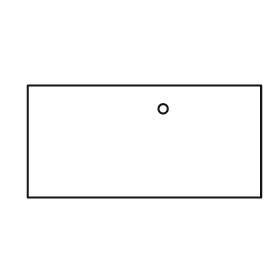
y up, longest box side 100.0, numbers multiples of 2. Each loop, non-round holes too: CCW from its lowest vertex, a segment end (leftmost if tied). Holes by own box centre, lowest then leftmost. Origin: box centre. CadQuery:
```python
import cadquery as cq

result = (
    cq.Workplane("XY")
    .moveTo(-50.0, -24.0)
    .lineTo(50.0, -24.0)
    .lineTo(50.0, 24.0)
    .lineTo(-50.0, 24.0)
    .close()
    .moveTo(8.0, 14.0)
    .circle(2.0)
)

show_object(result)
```